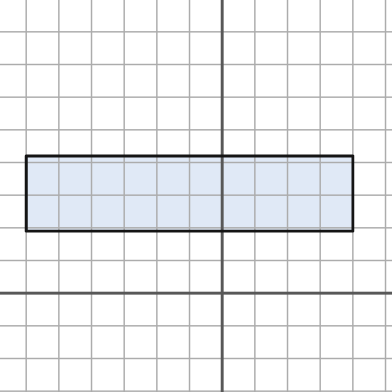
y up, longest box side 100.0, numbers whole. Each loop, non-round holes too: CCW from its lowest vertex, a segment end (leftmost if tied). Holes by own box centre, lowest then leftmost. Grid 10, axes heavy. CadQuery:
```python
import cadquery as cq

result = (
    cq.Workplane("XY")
    .moveTo(-60.0, 19.0)
    .lineTo(40.0, 19.0)
    .lineTo(40.0, 42.0)
    .lineTo(-60.0, 42.0)
    .close()
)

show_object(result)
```